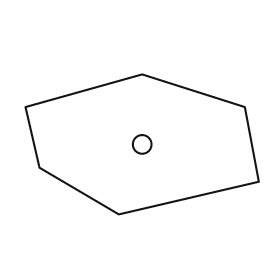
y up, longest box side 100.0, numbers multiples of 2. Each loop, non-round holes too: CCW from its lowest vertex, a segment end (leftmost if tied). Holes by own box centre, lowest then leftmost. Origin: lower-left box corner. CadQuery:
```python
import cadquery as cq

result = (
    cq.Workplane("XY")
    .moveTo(40.0, 0.0)
    .lineTo(100.0, 14.0)
    .lineTo(94.0, 46.0)
    .lineTo(50.0, 60.0)
    .lineTo(0.0, 46.0)
    .lineTo(6.0, 20.0)
    .close()
    .moveTo(50.0, 30.0)
    .circle(4.0)
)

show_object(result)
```